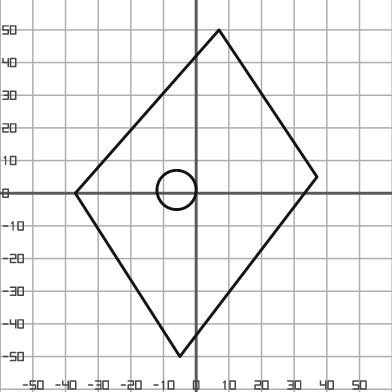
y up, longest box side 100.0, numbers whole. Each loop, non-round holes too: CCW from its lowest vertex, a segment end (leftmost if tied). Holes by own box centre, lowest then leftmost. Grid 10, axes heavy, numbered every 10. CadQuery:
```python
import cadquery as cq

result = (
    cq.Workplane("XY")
    .moveTo(-5.0, -50.0)
    .lineTo(37.0, 5.0)
    .lineTo(7.0, 50.0)
    .lineTo(-37.0, 0.0)
    .close()
    .moveTo(-6.0, 1.0)
    .circle(6.0)
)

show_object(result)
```